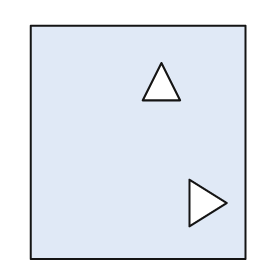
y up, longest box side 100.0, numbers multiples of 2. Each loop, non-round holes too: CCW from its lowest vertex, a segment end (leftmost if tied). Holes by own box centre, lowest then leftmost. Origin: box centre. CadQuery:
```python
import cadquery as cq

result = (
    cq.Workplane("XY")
    .moveTo(-46.0, -50.0)
    .lineTo(46.0, -50.0)
    .lineTo(46.0, 50.0)
    .lineTo(-46.0, 50.0)
    .close()
    .moveTo(22.0, -36.0)
    .lineTo(38.0, -26.0)
    .lineTo(22.0, -16.0)
    .close()
    .moveTo(2.0, 18.0)
    .lineTo(18.0, 18.0)
    .lineTo(10.0, 34.0)
    .close()
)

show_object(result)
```